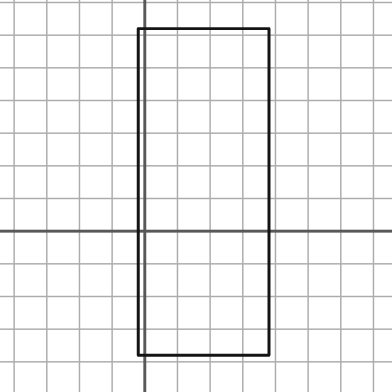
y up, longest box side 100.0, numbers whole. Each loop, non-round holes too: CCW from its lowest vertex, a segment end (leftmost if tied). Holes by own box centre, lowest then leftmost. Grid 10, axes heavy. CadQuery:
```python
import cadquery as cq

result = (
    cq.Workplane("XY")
    .moveTo(-2.0, -38.0)
    .lineTo(38.0, -38.0)
    .lineTo(38.0, 62.0)
    .lineTo(-2.0, 62.0)
    .close()
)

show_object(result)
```